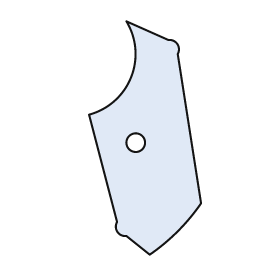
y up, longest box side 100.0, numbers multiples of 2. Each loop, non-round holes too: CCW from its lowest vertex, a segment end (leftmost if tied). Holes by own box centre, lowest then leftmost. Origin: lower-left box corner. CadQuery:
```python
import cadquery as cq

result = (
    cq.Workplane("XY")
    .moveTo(26.0, 0.0)
    .threePointArc((38.0, 10.0), (48.0, 22.0))
    .lineTo(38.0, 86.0)
    .threePointArc((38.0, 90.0), (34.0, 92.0))
    .lineTo(16.0, 100.0)
    .threePointArc((18.0, 76.0), (0.0, 60.0))
    .lineTo(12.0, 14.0)
    .threePointArc((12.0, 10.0), (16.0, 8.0))
    .close()
    .moveTo(20.0, 48.0)
    .circle(4.0)
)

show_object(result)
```